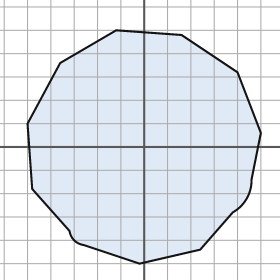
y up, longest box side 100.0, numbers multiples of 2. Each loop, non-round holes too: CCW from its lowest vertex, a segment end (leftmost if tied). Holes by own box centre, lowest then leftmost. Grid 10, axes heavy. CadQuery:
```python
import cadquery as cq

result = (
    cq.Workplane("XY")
    .moveTo(-2.0, -50.0)
    .lineTo(24.0, -44.0)
    .lineTo(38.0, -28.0)
    .threePointArc((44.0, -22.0), (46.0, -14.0))
    .lineTo(50.0, 6.0)
    .lineTo(40.0, 32.0)
    .lineTo(16.0, 48.0)
    .lineTo(-12.0, 50.0)
    .lineTo(-36.0, 36.0)
    .lineTo(-50.0, 10.0)
    .lineTo(-48.0, -18.0)
    .lineTo(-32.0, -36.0)
    .threePointArc((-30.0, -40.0), (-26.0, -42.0))
    .close()
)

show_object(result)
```